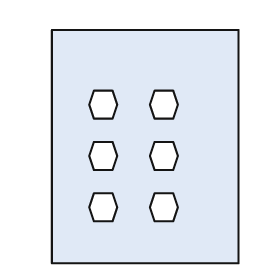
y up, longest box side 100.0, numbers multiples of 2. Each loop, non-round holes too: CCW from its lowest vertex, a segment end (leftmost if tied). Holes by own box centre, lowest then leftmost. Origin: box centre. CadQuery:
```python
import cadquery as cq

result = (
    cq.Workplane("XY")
    .moveTo(-40.0, -50.0)
    .lineTo(40.0, -50.0)
    .lineTo(40.0, 50.0)
    .lineTo(-40.0, 50.0)
    .close()
    .moveTo(-22.0, -32.0)
    .lineTo(-14.0, -32.0)
    .lineTo(-12.0, -26.0)
    .lineTo(-14.0, -20.0)
    .lineTo(-22.0, -20.0)
    .lineTo(-24.0, -26.0)
    .close()
    .moveTo(4.0, -32.0)
    .lineTo(12.0, -32.0)
    .lineTo(14.0, -26.0)
    .lineTo(12.0, -20.0)
    .lineTo(4.0, -20.0)
    .lineTo(2.0, -26.0)
    .close()
    .moveTo(-22.0, -10.0)
    .lineTo(-14.0, -10.0)
    .lineTo(-12.0, -4.0)
    .lineTo(-14.0, 2.0)
    .lineTo(-22.0, 2.0)
    .lineTo(-24.0, -4.0)
    .close()
    .moveTo(4.0, -10.0)
    .lineTo(12.0, -10.0)
    .lineTo(14.0, -4.0)
    .lineTo(12.0, 2.0)
    .lineTo(4.0, 2.0)
    .lineTo(2.0, -4.0)
    .close()
    .moveTo(-22.0, 12.0)
    .lineTo(-14.0, 12.0)
    .lineTo(-12.0, 18.0)
    .lineTo(-14.0, 24.0)
    .lineTo(-22.0, 24.0)
    .lineTo(-24.0, 18.0)
    .close()
    .moveTo(4.0, 12.0)
    .lineTo(12.0, 12.0)
    .lineTo(14.0, 18.0)
    .lineTo(12.0, 24.0)
    .lineTo(4.0, 24.0)
    .lineTo(2.0, 18.0)
    .close()
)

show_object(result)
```